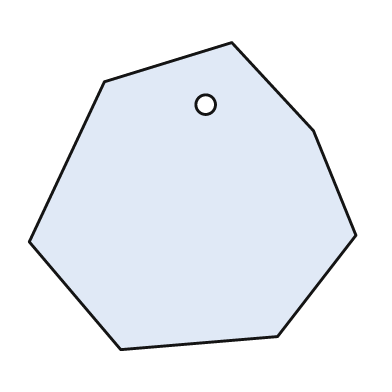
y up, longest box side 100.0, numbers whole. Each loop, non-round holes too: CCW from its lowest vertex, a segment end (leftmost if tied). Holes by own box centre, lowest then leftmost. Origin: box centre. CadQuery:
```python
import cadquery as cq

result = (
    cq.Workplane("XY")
    .moveTo(-22.0, -47.0)
    .lineTo(26.0, -43.0)
    .lineTo(50.0, -12.0)
    .lineTo(37.0, 20.0)
    .lineTo(12.0, 47.0)
    .lineTo(-27.0, 35.0)
    .lineTo(-50.0, -14.0)
    .close()
    .moveTo(4.0, 28.0)
    .circle(3.0)
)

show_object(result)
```